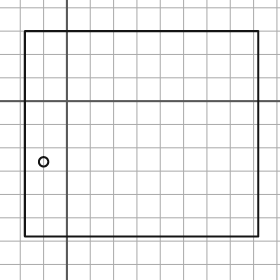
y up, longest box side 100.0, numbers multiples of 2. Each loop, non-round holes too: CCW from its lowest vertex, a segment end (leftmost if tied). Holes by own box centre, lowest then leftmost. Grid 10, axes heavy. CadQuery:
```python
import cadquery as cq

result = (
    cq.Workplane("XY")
    .moveTo(-18.0, -58.0)
    .lineTo(82.0, -58.0)
    .lineTo(82.0, 30.0)
    .lineTo(-18.0, 30.0)
    .close()
    .moveTo(-10.0, -26.0)
    .circle(2.0)
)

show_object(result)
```